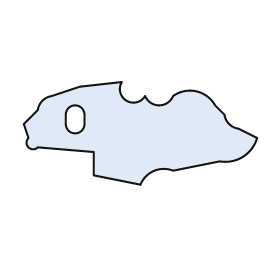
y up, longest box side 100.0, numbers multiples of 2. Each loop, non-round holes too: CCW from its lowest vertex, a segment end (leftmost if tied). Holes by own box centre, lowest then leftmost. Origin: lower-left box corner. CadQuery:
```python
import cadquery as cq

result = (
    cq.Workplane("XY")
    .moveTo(50.0, 0.0)
    .threePointArc((56.0, 6.0), (64.0, 6.0))
    .lineTo(84.0, 10.0)
    .threePointArc((94.0, 12.0), (100.0, 20.0))
    .lineTo(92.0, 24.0)
    .threePointArc((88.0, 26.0), (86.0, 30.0))
    .lineTo(82.0, 34.0)
    .threePointArc((74.0, 40.0), (64.0, 38.0))
    .threePointArc((58.0, 34.0), (52.0, 38.0))
    .threePointArc((44.0, 36.0), (42.0, 44.0))
    .lineTo(24.0, 42.0)
    .lineTo(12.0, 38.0)
    .threePointArc((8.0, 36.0), (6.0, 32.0))
    .lineTo(0.0, 26.0)
    .lineTo(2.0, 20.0)
    .threePointArc((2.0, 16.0), (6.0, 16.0))
    .lineTo(30.0, 14.0)
    .lineTo(30.0, 4.0)
    .close()
    .moveTo(18.0, 26.0)
    .threePointArc((22.0, 22.0), (26.0, 26.0))
    .lineTo(26.0, 30.0)
    .threePointArc((22.0, 34.0), (18.0, 30.0))
    .close()
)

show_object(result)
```